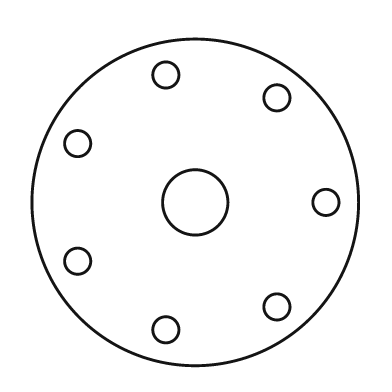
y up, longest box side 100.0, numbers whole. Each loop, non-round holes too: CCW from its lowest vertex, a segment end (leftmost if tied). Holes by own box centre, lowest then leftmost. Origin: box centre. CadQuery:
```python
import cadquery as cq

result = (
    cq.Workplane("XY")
    .moveTo(0.0, 0.0)
    .circle(50.0)
    .moveTo(-9.0, -39.0)
    .circle(4.0)
    .moveTo(25.0, -32.0)
    .circle(4.0)
    .moveTo(-36.0, -18.0)
    .circle(4.0)
    .moveTo(0.0, 0.0)
    .circle(10.0)
    .moveTo(40.0, 0.0)
    .circle(4.0)
    .moveTo(-36.0, 18.0)
    .circle(4.0)
    .moveTo(25.0, 32.0)
    .circle(4.0)
    .moveTo(-9.0, 39.0)
    .circle(4.0)
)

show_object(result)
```